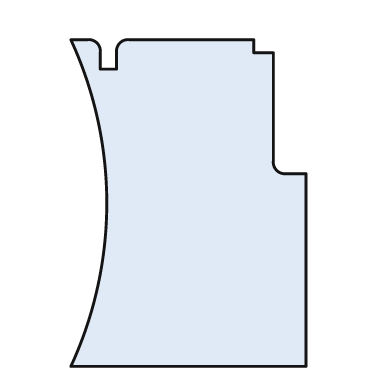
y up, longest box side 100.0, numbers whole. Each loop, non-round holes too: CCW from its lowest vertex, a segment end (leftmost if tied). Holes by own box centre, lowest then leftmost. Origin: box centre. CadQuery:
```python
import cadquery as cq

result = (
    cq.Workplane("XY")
    .moveTo(-36.0, -50.0)
    .lineTo(36.0, -50.0)
    .lineTo(36.0, 9.0)
    .lineTo(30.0, 9.0)
    .threePointArc((27.0, 10.0), (26.0, 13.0))
    .lineTo(26.0, 46.0)
    .lineTo(20.0, 46.0)
    .lineTo(20.0, 50.0)
    .lineTo(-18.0, 50.0)
    .threePointArc((-21.0, 49.0), (-22.0, 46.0))
    .lineTo(-22.0, 41.0)
    .lineTo(-27.0, 41.0)
    .lineTo(-27.0, 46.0)
    .threePointArc((-28.0, 49.0), (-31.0, 50.0))
    .lineTo(-36.0, 50.0)
    .threePointArc((-25.0, 0.0), (-36.0, -50.0))
    .close()
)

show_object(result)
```